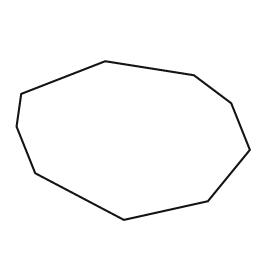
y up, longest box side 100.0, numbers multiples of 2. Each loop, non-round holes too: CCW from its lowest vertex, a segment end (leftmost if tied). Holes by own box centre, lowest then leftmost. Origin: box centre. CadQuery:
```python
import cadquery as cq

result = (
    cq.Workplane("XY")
    .moveTo(-4.0, -34.0)
    .lineTo(32.0, -26.0)
    .lineTo(50.0, -4.0)
    .lineTo(42.0, 16.0)
    .lineTo(26.0, 28.0)
    .lineTo(-12.0, 34.0)
    .lineTo(-48.0, 20.0)
    .lineTo(-50.0, 6.0)
    .lineTo(-42.0, -14.0)
    .close()
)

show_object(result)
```